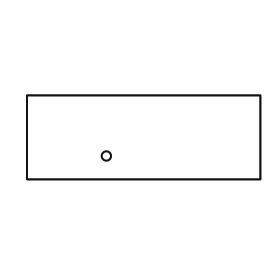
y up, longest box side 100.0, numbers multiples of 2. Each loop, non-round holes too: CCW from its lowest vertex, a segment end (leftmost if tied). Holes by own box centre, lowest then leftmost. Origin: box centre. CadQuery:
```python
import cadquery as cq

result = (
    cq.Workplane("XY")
    .moveTo(-50.0, -18.0)
    .lineTo(50.0, -18.0)
    .lineTo(50.0, 18.0)
    .lineTo(-50.0, 18.0)
    .close()
    .moveTo(-16.0, -8.0)
    .circle(2.0)
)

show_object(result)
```